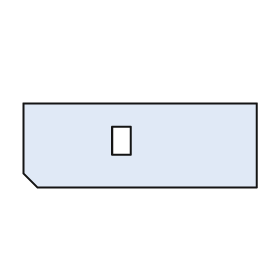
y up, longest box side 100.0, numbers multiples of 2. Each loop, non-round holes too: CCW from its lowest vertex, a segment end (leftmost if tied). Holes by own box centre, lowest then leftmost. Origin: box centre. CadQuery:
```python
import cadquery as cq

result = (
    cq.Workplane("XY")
    .moveTo(-44.0, -18.0)
    .lineTo(50.0, -18.0)
    .lineTo(50.0, 18.0)
    .lineTo(-50.0, 18.0)
    .lineTo(-50.0, -12.0)
    .close()
    .moveTo(-12.0, -4.0)
    .lineTo(-4.0, -4.0)
    .lineTo(-4.0, 8.0)
    .lineTo(-12.0, 8.0)
    .close()
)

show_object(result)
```